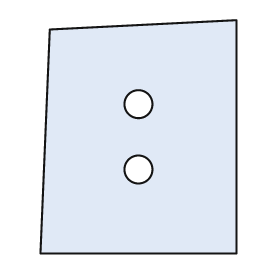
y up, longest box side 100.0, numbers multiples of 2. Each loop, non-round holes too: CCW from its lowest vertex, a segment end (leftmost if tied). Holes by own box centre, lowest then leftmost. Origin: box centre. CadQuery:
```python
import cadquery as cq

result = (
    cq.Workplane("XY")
    .moveTo(-42.0, -50.0)
    .lineTo(42.0, -50.0)
    .lineTo(42.0, 50.0)
    .lineTo(-38.0, 46.0)
    .close()
    .moveTo(0.0, -14.0)
    .circle(6.0)
    .moveTo(0.0, 14.0)
    .circle(6.0)
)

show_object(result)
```